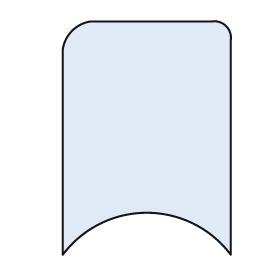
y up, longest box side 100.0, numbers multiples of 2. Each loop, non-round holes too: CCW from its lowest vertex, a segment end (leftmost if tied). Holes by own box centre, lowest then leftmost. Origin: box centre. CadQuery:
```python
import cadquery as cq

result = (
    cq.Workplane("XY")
    .moveTo(-36.0, -50.0)
    .threePointArc((0.0, -32.0), (36.0, -50.0))
    .lineTo(36.0, 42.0)
    .threePointArc((34.0, 48.0), (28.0, 50.0))
    .lineTo(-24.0, 50.0)
    .threePointArc((-32.0, 46.0), (-36.0, 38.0))
    .close()
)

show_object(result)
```